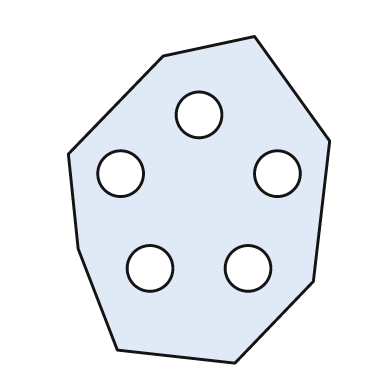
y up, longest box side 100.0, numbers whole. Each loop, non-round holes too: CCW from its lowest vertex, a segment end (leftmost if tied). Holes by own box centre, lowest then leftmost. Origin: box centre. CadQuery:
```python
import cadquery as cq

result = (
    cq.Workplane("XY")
    .moveTo(11.0, -50.0)
    .lineTo(35.0, -25.0)
    .lineTo(40.0, 18.0)
    .lineTo(17.0, 50.0)
    .lineTo(-11.0, 44.0)
    .lineTo(-40.0, 14.0)
    .lineTo(-37.0, -15.0)
    .lineTo(-25.0, -46.0)
    .close()
    .moveTo(-15.0, -21.0)
    .circle(7.0)
    .moveTo(15.0, -21.0)
    .circle(7.0)
    .moveTo(-24.0, 8.0)
    .circle(7.0)
    .moveTo(24.0, 8.0)
    .circle(7.0)
    .moveTo(0.0, 26.0)
    .circle(7.0)
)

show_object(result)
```